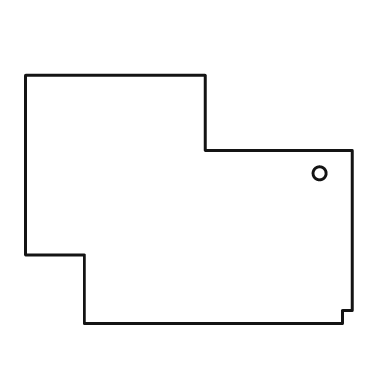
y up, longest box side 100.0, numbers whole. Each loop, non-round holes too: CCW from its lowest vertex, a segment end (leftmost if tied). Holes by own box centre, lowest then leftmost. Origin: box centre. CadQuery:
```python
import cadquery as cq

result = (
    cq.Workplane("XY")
    .moveTo(-32.0, -38.0)
    .lineTo(47.0, -38.0)
    .lineTo(47.0, -34.0)
    .lineTo(50.0, -34.0)
    .lineTo(50.0, 15.0)
    .lineTo(5.0, 15.0)
    .lineTo(5.0, 38.0)
    .lineTo(-50.0, 38.0)
    .lineTo(-50.0, -17.0)
    .lineTo(-32.0, -17.0)
    .close()
    .moveTo(40.0, 8.0)
    .circle(2.0)
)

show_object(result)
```